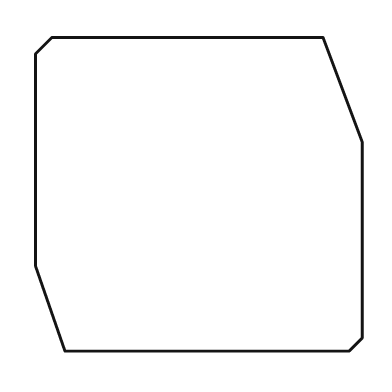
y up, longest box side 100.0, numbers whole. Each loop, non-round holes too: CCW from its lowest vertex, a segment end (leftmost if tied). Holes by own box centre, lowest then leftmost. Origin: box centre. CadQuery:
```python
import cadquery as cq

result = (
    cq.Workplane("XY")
    .moveTo(-41.0, -48.0)
    .lineTo(46.0, -48.0)
    .lineTo(50.0, -44.0)
    .lineTo(50.0, 16.0)
    .lineTo(38.0, 48.0)
    .lineTo(-45.0, 48.0)
    .lineTo(-50.0, 43.0)
    .lineTo(-50.0, -22.0)
    .close()
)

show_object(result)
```